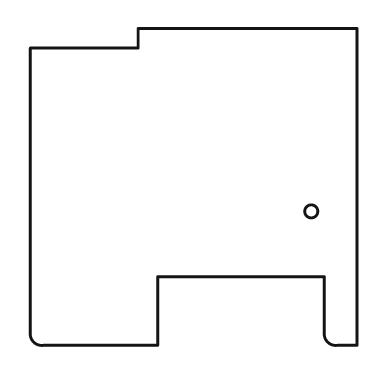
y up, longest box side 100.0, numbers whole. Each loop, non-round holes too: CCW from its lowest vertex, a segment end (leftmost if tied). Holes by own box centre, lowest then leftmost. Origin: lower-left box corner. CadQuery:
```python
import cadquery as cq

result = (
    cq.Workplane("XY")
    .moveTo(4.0, 0.0)
    .lineTo(39.0, 0.0)
    .lineTo(39.0, 21.0)
    .lineTo(90.0, 21.0)
    .lineTo(90.0, 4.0)
    .threePointArc((91.0, 1.0), (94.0, 0.0))
    .lineTo(100.0, 0.0)
    .lineTo(100.0, 97.0)
    .lineTo(33.0, 97.0)
    .lineTo(33.0, 91.0)
    .lineTo(0.0, 91.0)
    .lineTo(0.0, 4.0)
    .threePointArc((1.0, 1.0), (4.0, 0.0))
    .close()
    .moveTo(86.0, 41.0)
    .circle(2.0)
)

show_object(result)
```